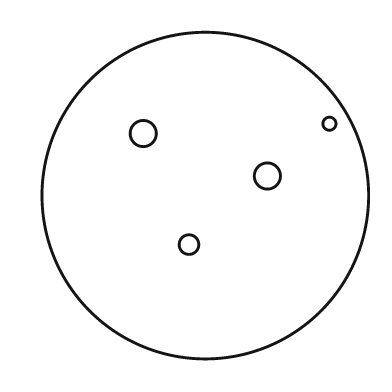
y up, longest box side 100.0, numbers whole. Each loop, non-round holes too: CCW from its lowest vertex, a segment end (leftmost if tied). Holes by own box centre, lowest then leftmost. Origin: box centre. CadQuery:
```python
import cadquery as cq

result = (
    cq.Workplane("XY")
    .moveTo(0.0, 0.0)
    .circle(50.0)
    .moveTo(-5.0, -15.0)
    .circle(3.0)
    .moveTo(19.0, 6.0)
    .circle(4.0)
    .moveTo(-19.0, 19.0)
    .circle(4.0)
    .moveTo(38.0, 22.0)
    .circle(2.0)
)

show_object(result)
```